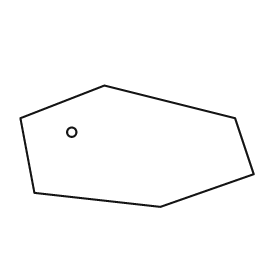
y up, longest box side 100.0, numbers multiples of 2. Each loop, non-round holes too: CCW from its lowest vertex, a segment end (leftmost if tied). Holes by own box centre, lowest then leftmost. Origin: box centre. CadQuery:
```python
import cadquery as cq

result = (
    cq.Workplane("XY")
    .moveTo(10.0, -26.0)
    .lineTo(50.0, -12.0)
    .lineTo(42.0, 12.0)
    .lineTo(-14.0, 26.0)
    .lineTo(-50.0, 12.0)
    .lineTo(-44.0, -20.0)
    .close()
    .moveTo(-28.0, 6.0)
    .circle(2.0)
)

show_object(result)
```